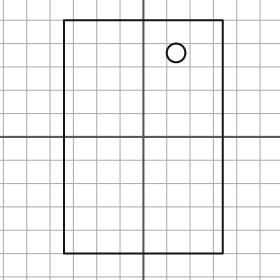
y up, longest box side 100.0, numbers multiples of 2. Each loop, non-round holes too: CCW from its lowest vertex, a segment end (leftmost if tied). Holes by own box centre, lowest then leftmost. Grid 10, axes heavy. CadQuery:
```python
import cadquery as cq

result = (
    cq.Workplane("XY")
    .moveTo(-34.0, -50.0)
    .lineTo(34.0, -50.0)
    .lineTo(34.0, 50.0)
    .lineTo(-34.0, 50.0)
    .close()
    .moveTo(14.0, 36.0)
    .circle(4.0)
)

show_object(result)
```